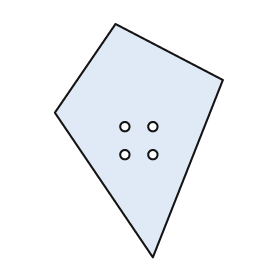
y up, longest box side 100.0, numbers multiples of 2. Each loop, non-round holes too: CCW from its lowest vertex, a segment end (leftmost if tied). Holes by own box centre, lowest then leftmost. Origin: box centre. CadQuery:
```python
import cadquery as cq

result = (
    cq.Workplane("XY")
    .moveTo(6.0, -50.0)
    .lineTo(36.0, 26.0)
    .lineTo(-10.0, 50.0)
    .lineTo(-36.0, 12.0)
    .close()
    .moveTo(-6.0, -6.0)
    .circle(2.0)
    .moveTo(6.0, -6.0)
    .circle(2.0)
    .moveTo(-6.0, 6.0)
    .circle(2.0)
    .moveTo(6.0, 6.0)
    .circle(2.0)
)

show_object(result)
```